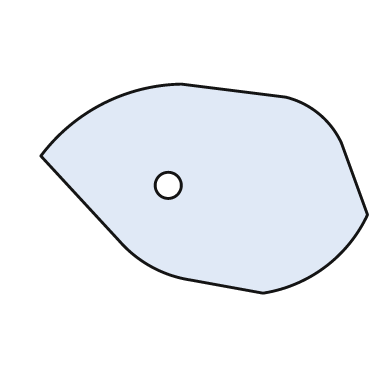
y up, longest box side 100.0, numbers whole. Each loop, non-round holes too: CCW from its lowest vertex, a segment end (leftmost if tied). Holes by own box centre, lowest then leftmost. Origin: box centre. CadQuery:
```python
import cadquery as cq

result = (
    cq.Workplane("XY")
    .moveTo(18.0, -32.0)
    .threePointArc((37.0, -24.0), (50.0, -8.0))
    .lineTo(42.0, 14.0)
    .threePointArc((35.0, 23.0), (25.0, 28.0))
    .lineTo(-7.0, 32.0)
    .threePointArc((-31.0, 26.0), (-50.0, 10.0))
    .lineTo(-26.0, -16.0)
    .threePointArc((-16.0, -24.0), (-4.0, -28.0))
    .close()
    .moveTo(-11.0, 1.0)
    .circle(4.0)
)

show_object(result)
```